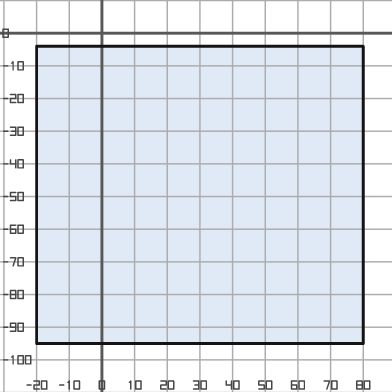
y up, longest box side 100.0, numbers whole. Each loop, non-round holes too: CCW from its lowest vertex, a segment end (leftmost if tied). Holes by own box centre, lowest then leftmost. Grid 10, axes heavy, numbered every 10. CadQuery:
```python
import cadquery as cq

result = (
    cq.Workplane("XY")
    .moveTo(-20.0, -95.0)
    .lineTo(80.0, -95.0)
    .lineTo(80.0, -4.0)
    .lineTo(-20.0, -4.0)
    .close()
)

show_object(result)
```